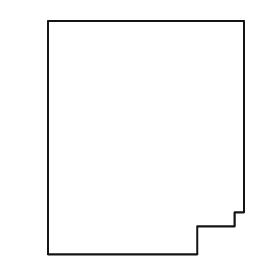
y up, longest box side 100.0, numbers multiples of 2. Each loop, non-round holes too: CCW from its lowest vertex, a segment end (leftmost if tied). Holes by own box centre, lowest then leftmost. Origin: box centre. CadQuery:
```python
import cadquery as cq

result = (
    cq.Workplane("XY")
    .moveTo(-42.0, -50.0)
    .lineTo(22.0, -50.0)
    .lineTo(22.0, -38.0)
    .lineTo(38.0, -38.0)
    .lineTo(38.0, -32.0)
    .lineTo(42.0, -32.0)
    .lineTo(42.0, 50.0)
    .lineTo(-42.0, 50.0)
    .close()
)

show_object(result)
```